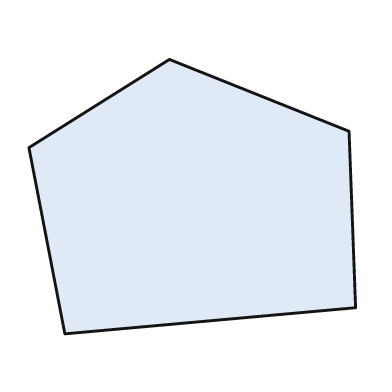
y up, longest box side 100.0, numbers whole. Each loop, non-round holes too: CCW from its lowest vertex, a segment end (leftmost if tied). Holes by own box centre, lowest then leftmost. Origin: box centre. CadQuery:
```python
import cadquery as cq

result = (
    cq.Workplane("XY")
    .moveTo(-39.0, -42.0)
    .lineTo(50.0, -34.0)
    .lineTo(48.0, 20.0)
    .lineTo(-7.0, 42.0)
    .lineTo(-50.0, 15.0)
    .close()
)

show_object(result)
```